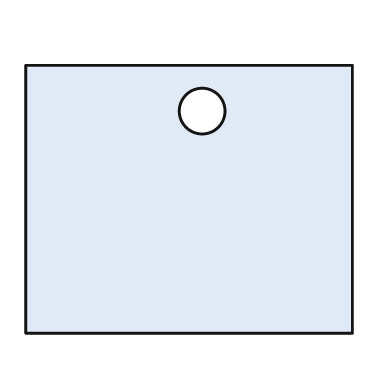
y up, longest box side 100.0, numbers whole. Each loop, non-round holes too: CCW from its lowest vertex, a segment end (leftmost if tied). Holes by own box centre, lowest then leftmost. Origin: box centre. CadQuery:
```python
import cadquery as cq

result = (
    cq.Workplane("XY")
    .moveTo(-50.0, -41.0)
    .lineTo(50.0, -41.0)
    .lineTo(50.0, 41.0)
    .lineTo(-50.0, 41.0)
    .close()
    .moveTo(4.0, 27.0)
    .circle(7.0)
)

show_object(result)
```